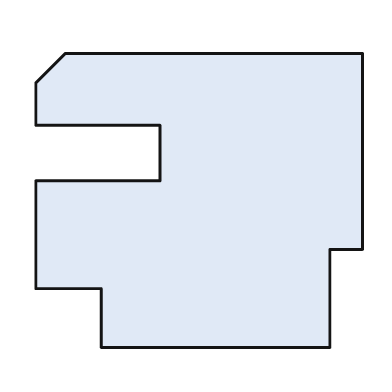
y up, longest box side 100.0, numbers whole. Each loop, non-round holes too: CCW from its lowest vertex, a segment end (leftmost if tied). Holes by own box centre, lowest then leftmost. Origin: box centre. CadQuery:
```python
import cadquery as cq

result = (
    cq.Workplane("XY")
    .moveTo(-30.0, -45.0)
    .lineTo(40.0, -45.0)
    .lineTo(40.0, -15.0)
    .lineTo(50.0, -15.0)
    .lineTo(50.0, 45.0)
    .lineTo(-41.0, 45.0)
    .lineTo(-50.0, 36.0)
    .lineTo(-50.0, 23.0)
    .lineTo(-12.0, 23.0)
    .lineTo(-12.0, 6.0)
    .lineTo(-50.0, 6.0)
    .lineTo(-50.0, -27.0)
    .lineTo(-30.0, -27.0)
    .close()
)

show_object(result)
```